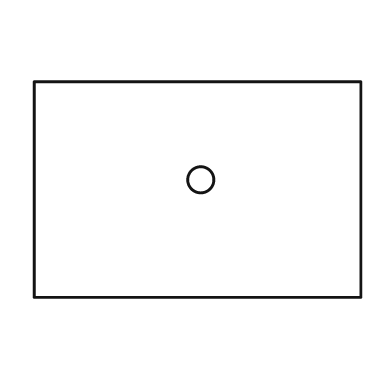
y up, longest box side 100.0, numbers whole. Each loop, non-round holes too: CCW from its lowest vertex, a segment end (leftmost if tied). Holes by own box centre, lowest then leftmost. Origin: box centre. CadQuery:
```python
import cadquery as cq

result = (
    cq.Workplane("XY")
    .moveTo(-50.0, -33.0)
    .lineTo(50.0, -33.0)
    .lineTo(50.0, 33.0)
    .lineTo(-50.0, 33.0)
    .close()
    .moveTo(1.0, 3.0)
    .circle(4.0)
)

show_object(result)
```